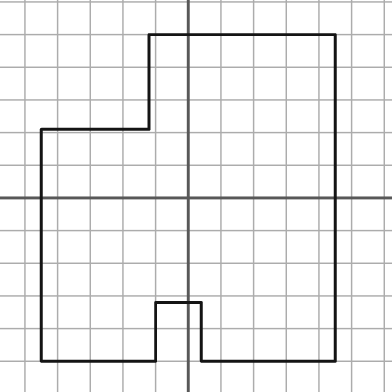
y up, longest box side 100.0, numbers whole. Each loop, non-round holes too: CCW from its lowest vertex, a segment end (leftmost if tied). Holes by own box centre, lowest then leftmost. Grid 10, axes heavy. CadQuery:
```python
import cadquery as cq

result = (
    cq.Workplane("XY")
    .moveTo(-45.0, -50.0)
    .lineTo(-10.0, -50.0)
    .lineTo(-10.0, -32.0)
    .lineTo(4.0, -32.0)
    .lineTo(4.0, -50.0)
    .lineTo(45.0, -50.0)
    .lineTo(45.0, 50.0)
    .lineTo(-12.0, 50.0)
    .lineTo(-12.0, 21.0)
    .lineTo(-45.0, 21.0)
    .close()
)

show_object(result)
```